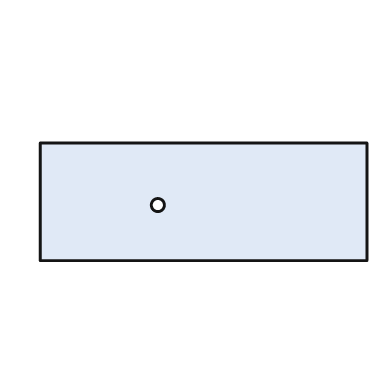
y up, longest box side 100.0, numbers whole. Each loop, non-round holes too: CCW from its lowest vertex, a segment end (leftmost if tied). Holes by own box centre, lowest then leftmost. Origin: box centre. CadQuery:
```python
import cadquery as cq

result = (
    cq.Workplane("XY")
    .moveTo(-50.0, -18.0)
    .lineTo(50.0, -18.0)
    .lineTo(50.0, 18.0)
    .lineTo(-50.0, 18.0)
    .close()
    .moveTo(-14.0, -1.0)
    .circle(2.0)
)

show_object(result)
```